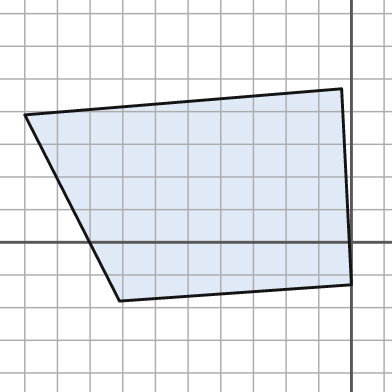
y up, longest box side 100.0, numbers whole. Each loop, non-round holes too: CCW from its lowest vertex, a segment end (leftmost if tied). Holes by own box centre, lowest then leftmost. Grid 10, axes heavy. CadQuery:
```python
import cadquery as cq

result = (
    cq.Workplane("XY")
    .moveTo(-71.0, -18.0)
    .lineTo(0.0, -13.0)
    .lineTo(-3.0, 47.0)
    .lineTo(-100.0, 39.0)
    .close()
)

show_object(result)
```